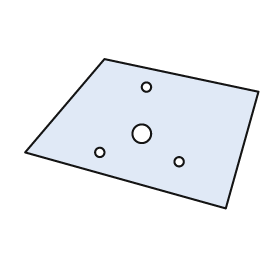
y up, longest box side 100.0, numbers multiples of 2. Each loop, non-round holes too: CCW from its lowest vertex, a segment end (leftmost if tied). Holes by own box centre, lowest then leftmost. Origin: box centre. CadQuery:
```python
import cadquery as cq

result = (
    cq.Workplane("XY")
    .moveTo(36.0, -32.0)
    .lineTo(50.0, 18.0)
    .lineTo(-16.0, 32.0)
    .lineTo(-50.0, -8.0)
    .close()
    .moveTo(16.0, -12.0)
    .circle(2.0)
    .moveTo(-18.0, -8.0)
    .circle(2.0)
    .moveTo(0.0, 0.0)
    .circle(4.0)
    .moveTo(2.0, 20.0)
    .circle(2.0)
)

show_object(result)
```